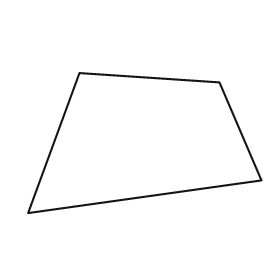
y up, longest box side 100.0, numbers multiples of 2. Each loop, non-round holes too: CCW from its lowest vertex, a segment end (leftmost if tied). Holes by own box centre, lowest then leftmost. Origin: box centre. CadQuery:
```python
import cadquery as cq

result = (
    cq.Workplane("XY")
    .moveTo(-50.0, -30.0)
    .lineTo(50.0, -16.0)
    .lineTo(32.0, 26.0)
    .lineTo(-28.0, 30.0)
    .close()
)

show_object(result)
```